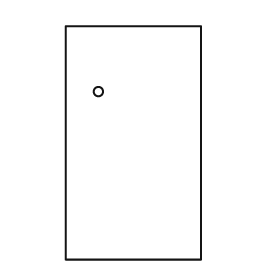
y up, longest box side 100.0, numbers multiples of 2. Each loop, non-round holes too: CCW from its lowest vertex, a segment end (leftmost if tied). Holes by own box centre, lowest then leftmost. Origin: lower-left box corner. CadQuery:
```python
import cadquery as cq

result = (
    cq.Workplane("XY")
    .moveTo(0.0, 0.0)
    .lineTo(58.0, 0.0)
    .lineTo(58.0, 100.0)
    .lineTo(0.0, 100.0)
    .close()
    .moveTo(14.0, 72.0)
    .circle(2.0)
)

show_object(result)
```